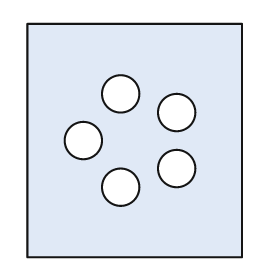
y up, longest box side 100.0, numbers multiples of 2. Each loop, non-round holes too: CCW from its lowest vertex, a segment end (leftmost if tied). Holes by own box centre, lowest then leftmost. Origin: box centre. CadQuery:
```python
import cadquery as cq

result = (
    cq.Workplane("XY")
    .moveTo(-46.0, -50.0)
    .lineTo(46.0, -50.0)
    .lineTo(46.0, 50.0)
    .lineTo(-46.0, 50.0)
    .close()
    .moveTo(-6.0, -20.0)
    .circle(8.0)
    .moveTo(18.0, -12.0)
    .circle(8.0)
    .moveTo(-22.0, 0.0)
    .circle(8.0)
    .moveTo(18.0, 12.0)
    .circle(8.0)
    .moveTo(-6.0, 20.0)
    .circle(8.0)
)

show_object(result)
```